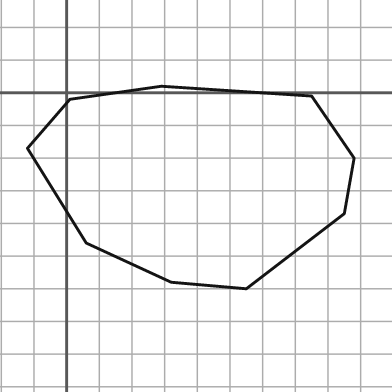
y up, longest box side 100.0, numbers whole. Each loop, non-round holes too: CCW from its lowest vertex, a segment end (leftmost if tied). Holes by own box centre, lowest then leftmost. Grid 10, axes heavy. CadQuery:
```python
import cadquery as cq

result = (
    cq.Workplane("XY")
    .moveTo(55.0, -60.0)
    .lineTo(85.0, -37.0)
    .lineTo(88.0, -20.0)
    .lineTo(75.0, -1.0)
    .lineTo(29.0, 2.0)
    .lineTo(1.0, -2.0)
    .lineTo(-12.0, -17.0)
    .lineTo(6.0, -46.0)
    .lineTo(32.0, -58.0)
    .close()
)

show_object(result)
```